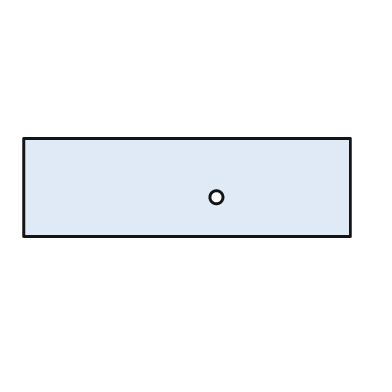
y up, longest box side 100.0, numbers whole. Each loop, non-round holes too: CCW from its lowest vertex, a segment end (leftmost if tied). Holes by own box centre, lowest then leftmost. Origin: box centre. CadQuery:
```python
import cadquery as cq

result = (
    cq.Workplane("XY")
    .moveTo(-50.0, -15.0)
    .lineTo(50.0, -15.0)
    .lineTo(50.0, 15.0)
    .lineTo(-50.0, 15.0)
    .close()
    .moveTo(9.0, -3.0)
    .circle(2.0)
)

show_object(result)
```